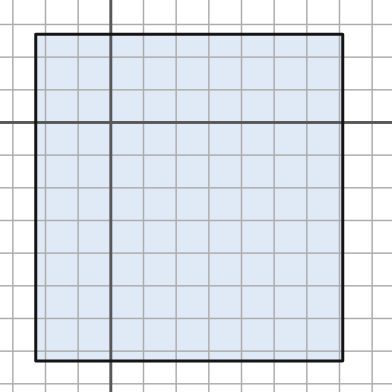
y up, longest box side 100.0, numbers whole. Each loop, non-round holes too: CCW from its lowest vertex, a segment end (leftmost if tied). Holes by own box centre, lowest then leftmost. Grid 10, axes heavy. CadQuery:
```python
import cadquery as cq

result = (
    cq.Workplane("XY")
    .moveTo(-23.0, -73.0)
    .lineTo(71.0, -73.0)
    .lineTo(71.0, 27.0)
    .lineTo(-23.0, 27.0)
    .close()
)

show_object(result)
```